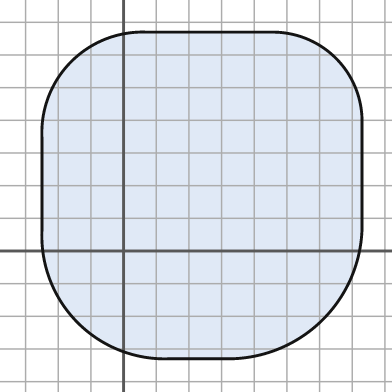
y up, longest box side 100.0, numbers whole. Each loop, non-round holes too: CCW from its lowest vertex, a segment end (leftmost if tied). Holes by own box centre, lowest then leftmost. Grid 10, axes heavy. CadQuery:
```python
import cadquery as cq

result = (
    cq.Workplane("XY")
    .moveTo(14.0, -33.0)
    .lineTo(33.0, -33.0)
    .threePointArc((61.0, -21.0), (73.0, 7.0))
    .lineTo(73.0, 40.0)
    .threePointArc((65.0, 59.0), (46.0, 67.0))
    .lineTo(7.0, 67.0)
    .threePointArc((-16.0, 58.0), (-25.0, 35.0))
    .lineTo(-25.0, 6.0)
    .threePointArc((-14.0, -22.0), (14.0, -33.0))
    .close()
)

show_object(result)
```